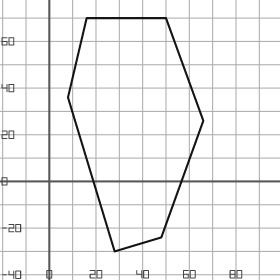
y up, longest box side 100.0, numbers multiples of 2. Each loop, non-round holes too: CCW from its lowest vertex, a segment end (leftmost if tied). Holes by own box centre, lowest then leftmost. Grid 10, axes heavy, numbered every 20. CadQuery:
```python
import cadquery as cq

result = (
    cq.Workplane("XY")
    .moveTo(28.0, -30.0)
    .lineTo(48.0, -24.0)
    .lineTo(66.0, 26.0)
    .lineTo(50.0, 70.0)
    .lineTo(16.0, 70.0)
    .lineTo(8.0, 36.0)
    .close()
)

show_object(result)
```